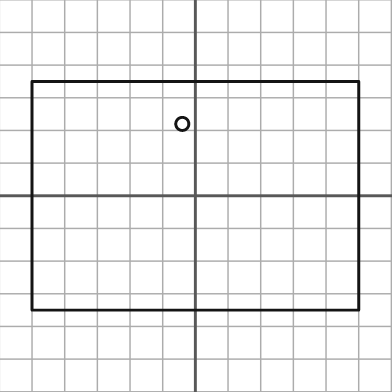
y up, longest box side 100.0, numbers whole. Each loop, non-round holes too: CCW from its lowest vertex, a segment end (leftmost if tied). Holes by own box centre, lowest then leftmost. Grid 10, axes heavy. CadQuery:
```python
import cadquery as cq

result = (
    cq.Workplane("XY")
    .moveTo(-50.0, -35.0)
    .lineTo(50.0, -35.0)
    .lineTo(50.0, 35.0)
    .lineTo(-50.0, 35.0)
    .close()
    .moveTo(-4.0, 22.0)
    .circle(2.0)
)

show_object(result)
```